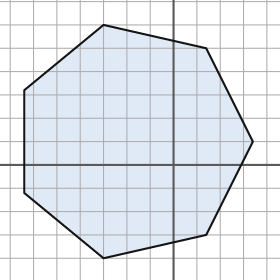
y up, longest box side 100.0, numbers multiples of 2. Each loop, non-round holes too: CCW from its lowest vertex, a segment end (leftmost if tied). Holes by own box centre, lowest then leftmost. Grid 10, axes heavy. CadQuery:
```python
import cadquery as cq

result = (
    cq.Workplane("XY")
    .moveTo(-30.0, -40.0)
    .lineTo(14.0, -30.0)
    .lineTo(34.0, 10.0)
    .lineTo(14.0, 50.0)
    .lineTo(-30.0, 60.0)
    .lineTo(-64.0, 32.0)
    .lineTo(-64.0, -12.0)
    .close()
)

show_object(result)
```